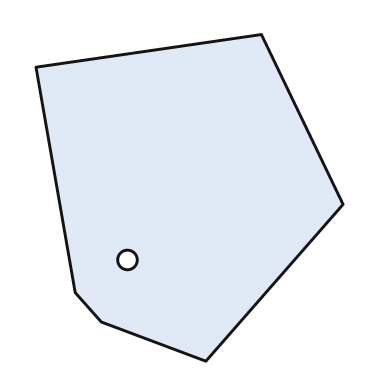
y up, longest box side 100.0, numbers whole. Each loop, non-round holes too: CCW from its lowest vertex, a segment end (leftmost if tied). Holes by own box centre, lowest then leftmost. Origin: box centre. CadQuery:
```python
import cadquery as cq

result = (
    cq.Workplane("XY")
    .moveTo(5.0, -50.0)
    .lineTo(47.0, -2.0)
    .lineTo(22.0, 50.0)
    .lineTo(-47.0, 40.0)
    .lineTo(-35.0, -29.0)
    .lineTo(-27.0, -38.0)
    .close()
    .moveTo(-19.0, -19.0)
    .circle(3.0)
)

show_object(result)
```